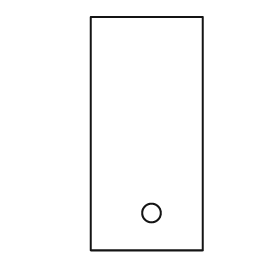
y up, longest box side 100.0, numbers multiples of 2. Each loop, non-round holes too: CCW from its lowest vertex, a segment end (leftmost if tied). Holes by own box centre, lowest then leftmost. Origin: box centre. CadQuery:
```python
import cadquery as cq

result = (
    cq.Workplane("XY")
    .moveTo(-24.0, -50.0)
    .lineTo(24.0, -50.0)
    .lineTo(24.0, 50.0)
    .lineTo(-24.0, 50.0)
    .close()
    .moveTo(2.0, -34.0)
    .circle(4.0)
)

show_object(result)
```